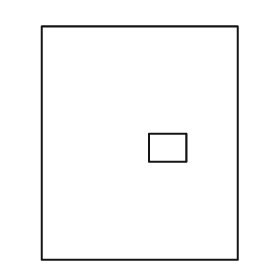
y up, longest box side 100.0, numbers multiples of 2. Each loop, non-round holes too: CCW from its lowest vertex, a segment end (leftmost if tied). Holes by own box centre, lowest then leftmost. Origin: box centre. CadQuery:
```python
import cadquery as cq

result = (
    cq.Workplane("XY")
    .moveTo(-42.0, -50.0)
    .lineTo(42.0, -50.0)
    .lineTo(42.0, 50.0)
    .lineTo(-42.0, 50.0)
    .close()
    .moveTo(4.0, -8.0)
    .lineTo(20.0, -8.0)
    .lineTo(20.0, 4.0)
    .lineTo(4.0, 4.0)
    .close()
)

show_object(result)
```